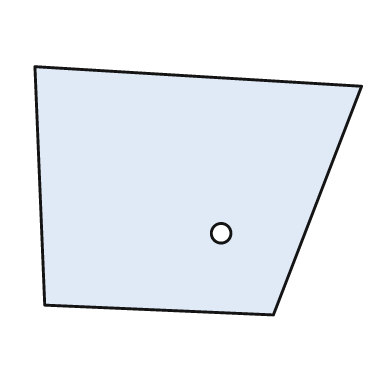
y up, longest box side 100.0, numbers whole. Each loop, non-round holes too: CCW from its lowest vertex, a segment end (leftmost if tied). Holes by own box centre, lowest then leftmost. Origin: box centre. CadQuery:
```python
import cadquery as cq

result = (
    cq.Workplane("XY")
    .moveTo(23.0, -38.0)
    .lineTo(50.0, 32.0)
    .lineTo(-50.0, 38.0)
    .lineTo(-47.0, -35.0)
    .close()
    .moveTo(7.0, -13.0)
    .circle(3.0)
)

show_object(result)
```